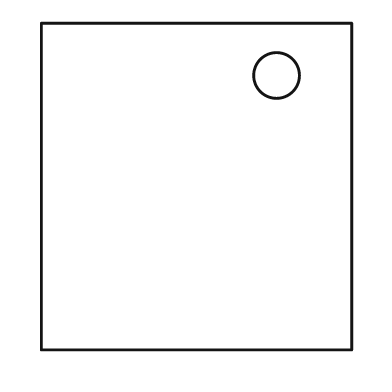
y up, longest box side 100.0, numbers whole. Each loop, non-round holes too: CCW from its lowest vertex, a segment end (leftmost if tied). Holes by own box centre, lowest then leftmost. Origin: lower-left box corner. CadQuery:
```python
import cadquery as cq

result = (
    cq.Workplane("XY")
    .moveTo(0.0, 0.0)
    .lineTo(95.0, 0.0)
    .lineTo(95.0, 100.0)
    .lineTo(0.0, 100.0)
    .close()
    .moveTo(72.0, 84.0)
    .circle(7.0)
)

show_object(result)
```